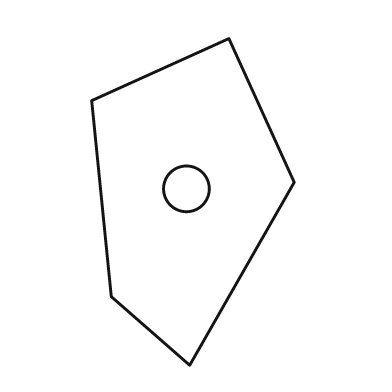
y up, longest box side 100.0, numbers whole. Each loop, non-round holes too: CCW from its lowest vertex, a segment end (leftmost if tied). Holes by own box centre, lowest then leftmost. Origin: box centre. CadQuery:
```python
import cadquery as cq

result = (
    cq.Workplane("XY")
    .moveTo(-1.0, -50.0)
    .lineTo(31.0, 6.0)
    .lineTo(11.0, 50.0)
    .lineTo(-31.0, 31.0)
    .lineTo(-25.0, -29.0)
    .close()
    .moveTo(-2.0, 4.0)
    .circle(7.0)
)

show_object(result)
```